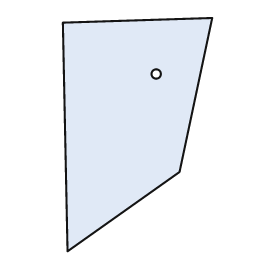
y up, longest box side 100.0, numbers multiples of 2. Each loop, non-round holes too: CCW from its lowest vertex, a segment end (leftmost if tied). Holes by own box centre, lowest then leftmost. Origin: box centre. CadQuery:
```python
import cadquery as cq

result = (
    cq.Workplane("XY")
    .moveTo(-30.0, -50.0)
    .lineTo(18.0, -16.0)
    .lineTo(32.0, 50.0)
    .lineTo(-32.0, 48.0)
    .close()
    .moveTo(8.0, 26.0)
    .circle(2.0)
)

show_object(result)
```